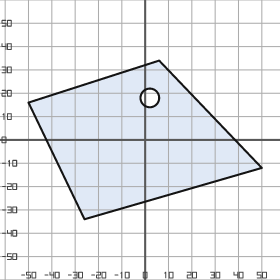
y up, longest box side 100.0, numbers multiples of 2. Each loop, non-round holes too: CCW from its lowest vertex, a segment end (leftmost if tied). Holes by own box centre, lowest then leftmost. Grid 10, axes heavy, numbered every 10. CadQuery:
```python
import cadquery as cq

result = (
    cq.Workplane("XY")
    .moveTo(-26.0, -34.0)
    .lineTo(50.0, -12.0)
    .lineTo(6.0, 34.0)
    .lineTo(-50.0, 16.0)
    .close()
    .moveTo(2.0, 18.0)
    .circle(4.0)
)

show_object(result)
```